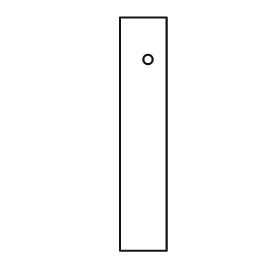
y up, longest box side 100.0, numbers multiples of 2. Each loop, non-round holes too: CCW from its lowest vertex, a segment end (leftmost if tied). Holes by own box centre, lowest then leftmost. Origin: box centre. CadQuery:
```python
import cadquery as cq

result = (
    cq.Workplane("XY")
    .moveTo(-10.0, -50.0)
    .lineTo(10.0, -50.0)
    .lineTo(10.0, 50.0)
    .lineTo(-10.0, 50.0)
    .close()
    .moveTo(2.0, 32.0)
    .circle(2.0)
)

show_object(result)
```